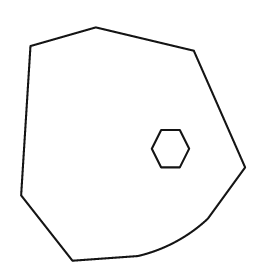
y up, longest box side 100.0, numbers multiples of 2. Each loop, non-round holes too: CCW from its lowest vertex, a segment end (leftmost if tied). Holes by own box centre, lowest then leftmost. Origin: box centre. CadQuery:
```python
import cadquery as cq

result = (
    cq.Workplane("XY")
    .moveTo(-26.0, -50.0)
    .lineTo(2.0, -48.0)
    .threePointArc((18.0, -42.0), (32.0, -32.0))
    .lineTo(48.0, -10.0)
    .lineTo(26.0, 40.0)
    .lineTo(-16.0, 50.0)
    .lineTo(-44.0, 42.0)
    .lineTo(-48.0, -22.0)
    .close()
    .moveTo(12.0, -10.0)
    .lineTo(20.0, -10.0)
    .lineTo(24.0, -2.0)
    .lineTo(20.0, 6.0)
    .lineTo(12.0, 6.0)
    .lineTo(8.0, -2.0)
    .close()
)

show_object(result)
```